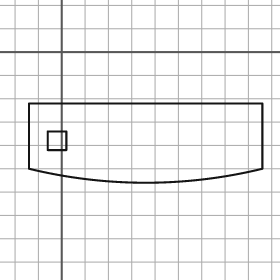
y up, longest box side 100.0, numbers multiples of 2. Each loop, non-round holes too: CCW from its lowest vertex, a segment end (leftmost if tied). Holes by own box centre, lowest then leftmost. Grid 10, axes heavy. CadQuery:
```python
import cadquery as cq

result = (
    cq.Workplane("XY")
    .moveTo(-14.0, -50.0)
    .threePointArc((36.0, -56.0), (86.0, -50.0))
    .lineTo(86.0, -22.0)
    .lineTo(-14.0, -22.0)
    .close()
    .moveTo(-6.0, -42.0)
    .lineTo(2.0, -42.0)
    .lineTo(2.0, -34.0)
    .lineTo(-6.0, -34.0)
    .close()
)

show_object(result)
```